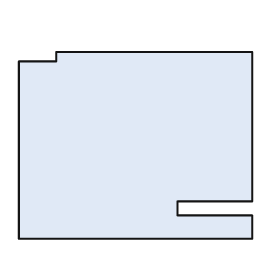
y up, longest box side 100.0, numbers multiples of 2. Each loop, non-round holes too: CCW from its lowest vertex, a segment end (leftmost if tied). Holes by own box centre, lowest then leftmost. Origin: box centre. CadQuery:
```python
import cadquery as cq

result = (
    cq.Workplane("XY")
    .moveTo(-50.0, -40.0)
    .lineTo(50.0, -40.0)
    .lineTo(50.0, -30.0)
    .lineTo(18.0, -30.0)
    .lineTo(18.0, -24.0)
    .lineTo(50.0, -24.0)
    .lineTo(50.0, 40.0)
    .lineTo(-34.0, 40.0)
    .lineTo(-34.0, 36.0)
    .lineTo(-50.0, 36.0)
    .close()
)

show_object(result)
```